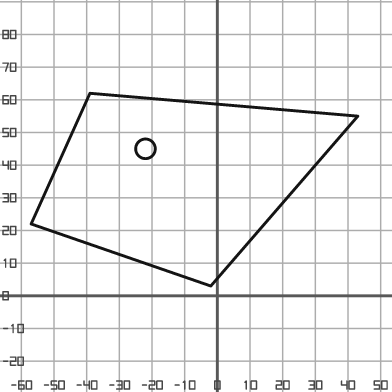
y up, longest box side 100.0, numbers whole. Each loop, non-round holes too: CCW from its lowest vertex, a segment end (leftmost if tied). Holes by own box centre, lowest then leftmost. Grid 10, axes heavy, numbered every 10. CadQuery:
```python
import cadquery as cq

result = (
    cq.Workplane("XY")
    .moveTo(-2.0, 3.0)
    .lineTo(43.0, 55.0)
    .lineTo(-39.0, 62.0)
    .lineTo(-57.0, 22.0)
    .close()
    .moveTo(-22.0, 45.0)
    .circle(3.0)
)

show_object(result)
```